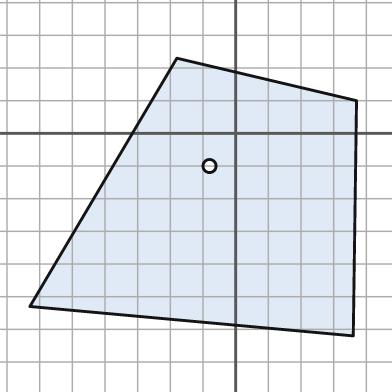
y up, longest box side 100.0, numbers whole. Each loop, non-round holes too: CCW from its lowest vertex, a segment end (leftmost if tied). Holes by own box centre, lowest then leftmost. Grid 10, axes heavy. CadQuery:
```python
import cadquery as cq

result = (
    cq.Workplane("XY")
    .moveTo(36.0, -62.0)
    .lineTo(37.0, 10.0)
    .lineTo(-18.0, 23.0)
    .lineTo(-63.0, -53.0)
    .close()
    .moveTo(-8.0, -10.0)
    .circle(2.0)
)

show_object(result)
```